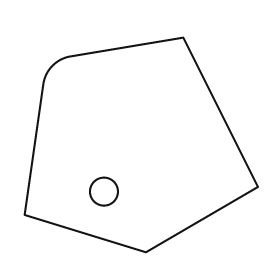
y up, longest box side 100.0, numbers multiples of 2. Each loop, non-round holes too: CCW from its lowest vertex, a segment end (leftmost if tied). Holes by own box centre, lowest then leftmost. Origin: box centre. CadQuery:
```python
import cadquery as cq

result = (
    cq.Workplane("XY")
    .moveTo(2.0, -46.0)
    .lineTo(50.0, -18.0)
    .lineTo(18.0, 46.0)
    .lineTo(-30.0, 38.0)
    .threePointArc((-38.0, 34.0), (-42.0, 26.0))
    .lineTo(-50.0, -30.0)
    .close()
    .moveTo(-16.0, -20.0)
    .circle(6.0)
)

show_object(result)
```